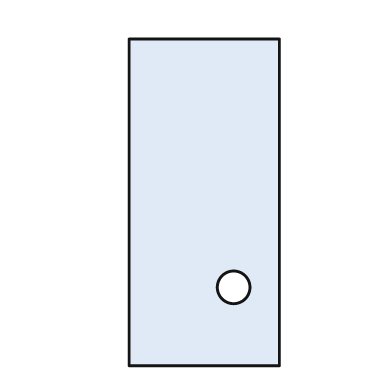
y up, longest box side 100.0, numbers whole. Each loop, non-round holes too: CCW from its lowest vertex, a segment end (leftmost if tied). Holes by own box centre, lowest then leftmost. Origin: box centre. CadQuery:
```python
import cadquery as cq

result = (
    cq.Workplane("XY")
    .moveTo(-23.0, -50.0)
    .lineTo(23.0, -50.0)
    .lineTo(23.0, 50.0)
    .lineTo(-23.0, 50.0)
    .close()
    .moveTo(9.0, -26.0)
    .circle(5.0)
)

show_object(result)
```